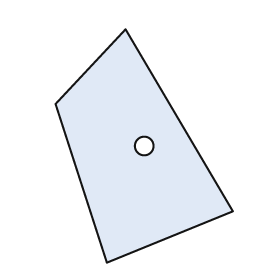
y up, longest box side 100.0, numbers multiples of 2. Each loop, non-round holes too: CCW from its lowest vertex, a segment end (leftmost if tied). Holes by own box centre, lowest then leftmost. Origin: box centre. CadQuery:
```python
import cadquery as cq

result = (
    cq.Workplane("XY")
    .moveTo(-16.0, -50.0)
    .lineTo(38.0, -28.0)
    .lineTo(-8.0, 50.0)
    .lineTo(-38.0, 18.0)
    .close()
    .moveTo(0.0, 0.0)
    .circle(4.0)
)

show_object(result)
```